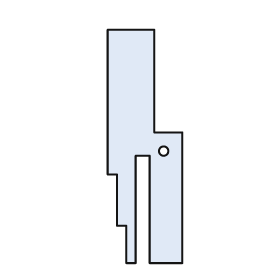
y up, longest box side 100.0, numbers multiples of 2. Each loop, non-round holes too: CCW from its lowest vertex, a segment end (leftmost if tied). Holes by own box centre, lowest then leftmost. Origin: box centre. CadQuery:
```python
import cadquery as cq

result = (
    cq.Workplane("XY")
    .moveTo(-8.0, -50.0)
    .lineTo(-4.0, -50.0)
    .lineTo(-4.0, -4.0)
    .lineTo(2.0, -4.0)
    .lineTo(2.0, -50.0)
    .lineTo(16.0, -50.0)
    .lineTo(16.0, 6.0)
    .lineTo(4.0, 6.0)
    .lineTo(4.0, 50.0)
    .lineTo(-16.0, 50.0)
    .lineTo(-16.0, -12.0)
    .lineTo(-12.0, -12.0)
    .lineTo(-12.0, -34.0)
    .lineTo(-8.0, -34.0)
    .close()
    .moveTo(8.0, -2.0)
    .circle(2.0)
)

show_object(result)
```